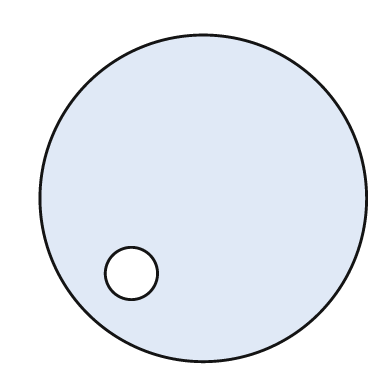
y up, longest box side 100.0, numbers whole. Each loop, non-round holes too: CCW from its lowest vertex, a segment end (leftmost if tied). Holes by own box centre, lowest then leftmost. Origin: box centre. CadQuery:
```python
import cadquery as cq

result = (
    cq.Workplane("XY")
    .moveTo(0.0, 0.0)
    .circle(50.0)
    .moveTo(-22.0, -23.0)
    .circle(8.0)
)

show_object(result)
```